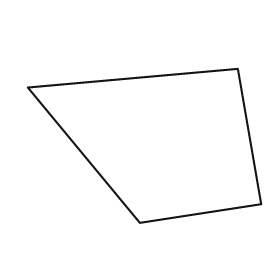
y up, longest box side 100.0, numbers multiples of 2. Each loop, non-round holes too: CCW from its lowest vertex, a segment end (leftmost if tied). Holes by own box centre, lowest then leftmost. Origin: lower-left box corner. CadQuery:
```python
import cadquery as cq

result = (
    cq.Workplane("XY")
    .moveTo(48.0, 0.0)
    .lineTo(100.0, 8.0)
    .lineTo(90.0, 66.0)
    .lineTo(0.0, 58.0)
    .close()
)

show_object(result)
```